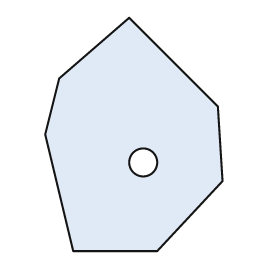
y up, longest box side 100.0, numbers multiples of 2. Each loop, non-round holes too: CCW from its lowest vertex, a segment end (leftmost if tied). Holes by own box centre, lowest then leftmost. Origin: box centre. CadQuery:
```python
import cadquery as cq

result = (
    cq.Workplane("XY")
    .moveTo(-26.0, -50.0)
    .lineTo(10.0, -50.0)
    .lineTo(38.0, -20.0)
    .lineTo(36.0, 12.0)
    .lineTo(-2.0, 50.0)
    .lineTo(-32.0, 24.0)
    .lineTo(-38.0, 0.0)
    .close()
    .moveTo(4.0, -12.0)
    .circle(6.0)
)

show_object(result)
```